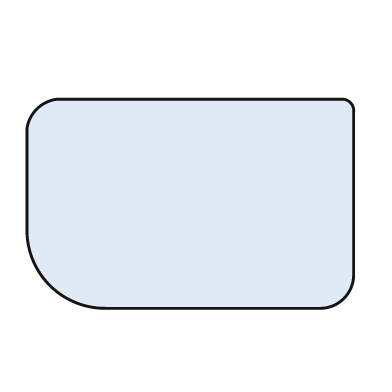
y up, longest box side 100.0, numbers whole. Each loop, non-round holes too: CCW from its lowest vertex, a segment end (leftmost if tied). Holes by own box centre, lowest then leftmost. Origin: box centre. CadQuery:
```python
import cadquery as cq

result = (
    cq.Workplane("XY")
    .moveTo(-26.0, -32.0)
    .lineTo(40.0, -32.0)
    .threePointArc((47.0, -29.0), (50.0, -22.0))
    .lineTo(50.0, 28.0)
    .threePointArc((49.0, 31.0), (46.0, 32.0))
    .lineTo(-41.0, 32.0)
    .threePointArc((-47.0, 29.0), (-50.0, 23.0))
    .lineTo(-50.0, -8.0)
    .threePointArc((-43.0, -25.0), (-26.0, -32.0))
    .close()
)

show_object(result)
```